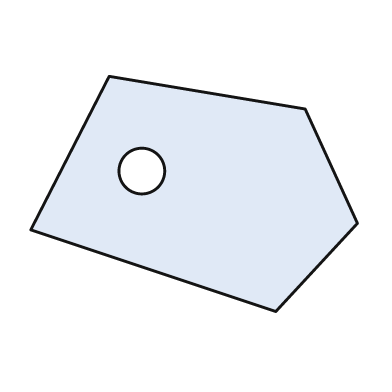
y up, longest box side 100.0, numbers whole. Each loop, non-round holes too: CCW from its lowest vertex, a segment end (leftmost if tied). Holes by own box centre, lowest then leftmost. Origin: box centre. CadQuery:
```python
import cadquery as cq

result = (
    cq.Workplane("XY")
    .moveTo(25.0, -36.0)
    .lineTo(50.0, -9.0)
    .lineTo(34.0, 26.0)
    .lineTo(-26.0, 36.0)
    .lineTo(-50.0, -11.0)
    .close()
    .moveTo(-16.0, 7.0)
    .circle(7.0)
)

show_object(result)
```